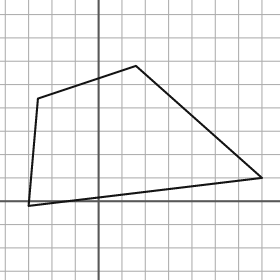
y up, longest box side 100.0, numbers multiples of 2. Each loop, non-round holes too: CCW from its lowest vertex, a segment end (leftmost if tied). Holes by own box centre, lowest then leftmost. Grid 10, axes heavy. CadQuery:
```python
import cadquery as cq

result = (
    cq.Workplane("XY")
    .moveTo(-30.0, -2.0)
    .lineTo(70.0, 10.0)
    .lineTo(16.0, 58.0)
    .lineTo(-26.0, 44.0)
    .close()
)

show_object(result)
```